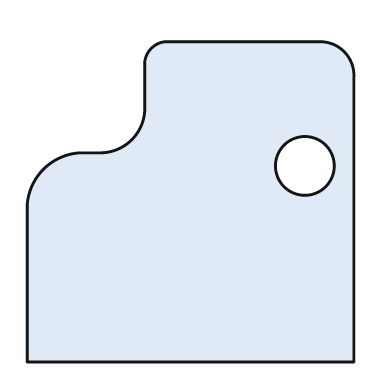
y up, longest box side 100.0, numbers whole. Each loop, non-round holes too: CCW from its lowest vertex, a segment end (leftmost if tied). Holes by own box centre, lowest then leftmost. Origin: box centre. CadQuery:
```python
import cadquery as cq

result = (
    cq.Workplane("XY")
    .moveTo(-50.0, -49.0)
    .lineTo(50.0, -49.0)
    .lineTo(50.0, 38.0)
    .threePointArc((47.0, 46.0), (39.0, 49.0))
    .lineTo(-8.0, 49.0)
    .threePointArc((-12.0, 47.0), (-14.0, 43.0))
    .lineTo(-14.0, 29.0)
    .threePointArc((-18.0, 19.0), (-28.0, 15.0))
    .lineTo(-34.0, 15.0)
    .threePointArc((-45.0, 10.0), (-50.0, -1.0))
    .close()
    .moveTo(35.0, 11.0)
    .circle(9.0)
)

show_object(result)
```